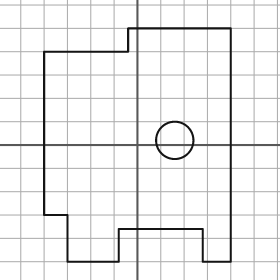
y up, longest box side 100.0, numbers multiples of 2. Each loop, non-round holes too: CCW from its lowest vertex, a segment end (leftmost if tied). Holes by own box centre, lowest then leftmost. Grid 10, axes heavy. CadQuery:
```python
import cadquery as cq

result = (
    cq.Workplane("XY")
    .moveTo(-30.0, -50.0)
    .lineTo(-8.0, -50.0)
    .lineTo(-8.0, -36.0)
    .lineTo(28.0, -36.0)
    .lineTo(28.0, -50.0)
    .lineTo(40.0, -50.0)
    .lineTo(40.0, 50.0)
    .lineTo(-4.0, 50.0)
    .lineTo(-4.0, 40.0)
    .lineTo(-40.0, 40.0)
    .lineTo(-40.0, -30.0)
    .lineTo(-30.0, -30.0)
    .close()
    .moveTo(16.0, 2.0)
    .circle(8.0)
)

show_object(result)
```